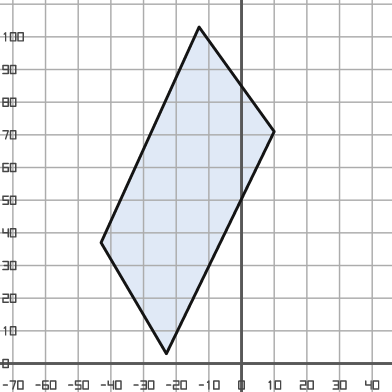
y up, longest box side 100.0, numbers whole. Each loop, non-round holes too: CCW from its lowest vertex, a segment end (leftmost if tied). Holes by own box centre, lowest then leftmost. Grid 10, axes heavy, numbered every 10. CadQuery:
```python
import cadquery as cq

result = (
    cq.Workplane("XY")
    .moveTo(-23.0, 3.0)
    .lineTo(10.0, 71.0)
    .lineTo(-13.0, 103.0)
    .lineTo(-43.0, 37.0)
    .close()
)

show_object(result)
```